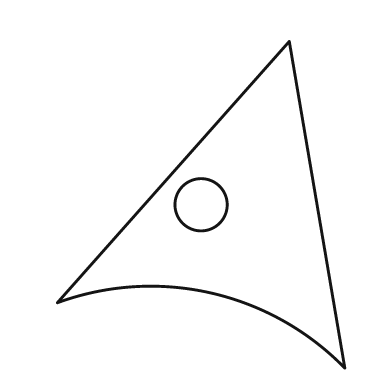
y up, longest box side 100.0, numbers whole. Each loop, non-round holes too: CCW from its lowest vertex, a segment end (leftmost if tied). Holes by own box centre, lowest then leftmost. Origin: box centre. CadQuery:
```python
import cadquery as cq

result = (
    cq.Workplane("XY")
    .moveTo(44.0, -50.0)
    .lineTo(27.0, 50.0)
    .lineTo(-44.0, -30.0)
    .threePointArc((3.0, -27.0), (44.0, -50.0))
    .close()
    .moveTo(0.0, 0.0)
    .circle(8.0)
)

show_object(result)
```